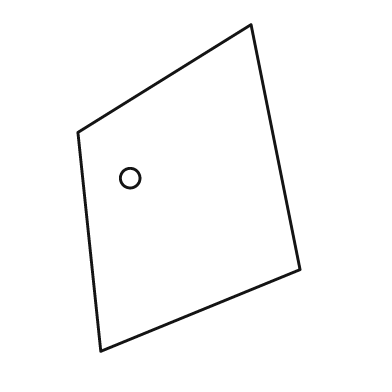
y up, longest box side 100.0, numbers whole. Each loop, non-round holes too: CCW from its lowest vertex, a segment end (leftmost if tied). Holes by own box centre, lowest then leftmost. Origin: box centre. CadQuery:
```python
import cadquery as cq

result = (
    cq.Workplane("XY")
    .moveTo(-27.0, -50.0)
    .lineTo(34.0, -25.0)
    .lineTo(19.0, 50.0)
    .lineTo(-34.0, 17.0)
    .close()
    .moveTo(-18.0, 3.0)
    .circle(3.0)
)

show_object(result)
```